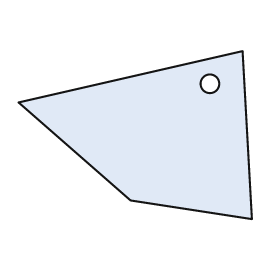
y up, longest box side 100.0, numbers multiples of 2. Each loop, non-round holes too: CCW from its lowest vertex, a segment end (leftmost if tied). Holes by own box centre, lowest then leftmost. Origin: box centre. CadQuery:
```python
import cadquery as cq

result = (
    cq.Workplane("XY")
    .moveTo(50.0, -36.0)
    .lineTo(46.0, 36.0)
    .lineTo(-50.0, 14.0)
    .lineTo(-2.0, -28.0)
    .close()
    .moveTo(32.0, 22.0)
    .circle(4.0)
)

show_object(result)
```